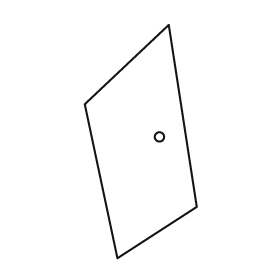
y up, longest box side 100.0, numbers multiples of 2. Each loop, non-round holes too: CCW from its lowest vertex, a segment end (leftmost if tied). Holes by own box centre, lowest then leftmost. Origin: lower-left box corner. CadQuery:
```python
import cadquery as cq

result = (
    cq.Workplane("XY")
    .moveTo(14.0, 0.0)
    .lineTo(48.0, 22.0)
    .lineTo(36.0, 100.0)
    .lineTo(0.0, 66.0)
    .close()
    .moveTo(32.0, 52.0)
    .circle(2.0)
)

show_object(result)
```